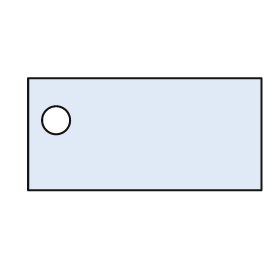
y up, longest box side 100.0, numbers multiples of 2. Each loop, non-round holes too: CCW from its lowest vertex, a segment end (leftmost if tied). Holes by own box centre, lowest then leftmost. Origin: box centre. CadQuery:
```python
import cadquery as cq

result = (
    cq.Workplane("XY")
    .moveTo(-50.0, -24.0)
    .lineTo(50.0, -24.0)
    .lineTo(50.0, 24.0)
    .lineTo(-50.0, 24.0)
    .close()
    .moveTo(-38.0, 6.0)
    .circle(6.0)
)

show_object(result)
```